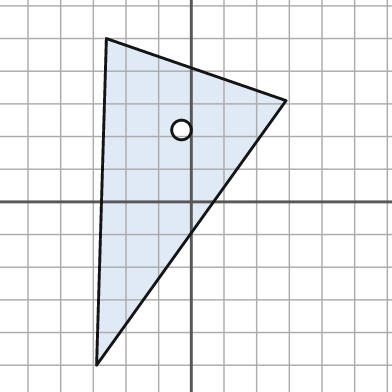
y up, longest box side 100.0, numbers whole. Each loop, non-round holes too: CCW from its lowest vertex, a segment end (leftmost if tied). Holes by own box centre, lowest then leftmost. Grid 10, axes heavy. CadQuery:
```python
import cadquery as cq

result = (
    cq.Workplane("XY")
    .moveTo(-29.0, -50.0)
    .lineTo(29.0, 31.0)
    .lineTo(-26.0, 50.0)
    .close()
    .moveTo(-3.0, 22.0)
    .circle(3.0)
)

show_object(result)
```